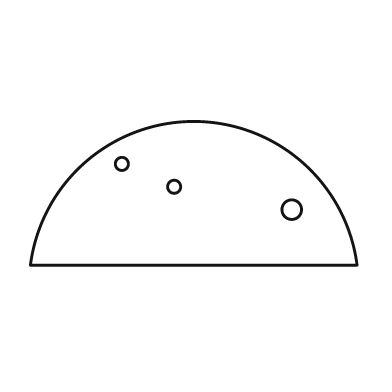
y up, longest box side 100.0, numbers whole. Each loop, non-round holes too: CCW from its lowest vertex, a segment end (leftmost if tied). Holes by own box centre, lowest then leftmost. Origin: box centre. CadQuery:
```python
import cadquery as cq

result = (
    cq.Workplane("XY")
    .moveTo(-50.0, -22.0)
    .lineTo(50.0, -22.0)
    .threePointArc((0.0, 22.0), (-50.0, -22.0))
    .close()
    .moveTo(30.0, -5.0)
    .circle(3.0)
    .moveTo(-6.0, 2.0)
    .circle(2.0)
    .moveTo(-22.0, 9.0)
    .circle(2.0)
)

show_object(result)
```